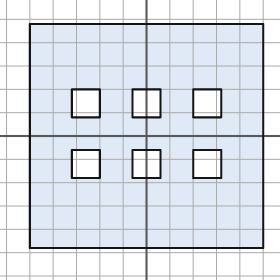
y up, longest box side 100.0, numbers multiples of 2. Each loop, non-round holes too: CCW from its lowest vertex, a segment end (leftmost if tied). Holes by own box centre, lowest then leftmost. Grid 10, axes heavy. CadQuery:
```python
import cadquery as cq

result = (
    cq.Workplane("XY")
    .moveTo(-50.0, -48.0)
    .lineTo(50.0, -48.0)
    .lineTo(50.0, 48.0)
    .lineTo(-50.0, 48.0)
    .close()
    .moveTo(-32.0, -18.0)
    .lineTo(-20.0, -18.0)
    .lineTo(-20.0, -6.0)
    .lineTo(-32.0, -6.0)
    .close()
    .moveTo(-6.0, -18.0)
    .lineTo(6.0, -18.0)
    .lineTo(6.0, -6.0)
    .lineTo(-6.0, -6.0)
    .close()
    .moveTo(20.0, -18.0)
    .lineTo(32.0, -18.0)
    .lineTo(32.0, -6.0)
    .lineTo(20.0, -6.0)
    .close()
    .moveTo(-32.0, 8.0)
    .lineTo(-20.0, 8.0)
    .lineTo(-20.0, 20.0)
    .lineTo(-32.0, 20.0)
    .close()
    .moveTo(-6.0, 8.0)
    .lineTo(6.0, 8.0)
    .lineTo(6.0, 20.0)
    .lineTo(-6.0, 20.0)
    .close()
    .moveTo(20.0, 8.0)
    .lineTo(32.0, 8.0)
    .lineTo(32.0, 20.0)
    .lineTo(20.0, 20.0)
    .close()
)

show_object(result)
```